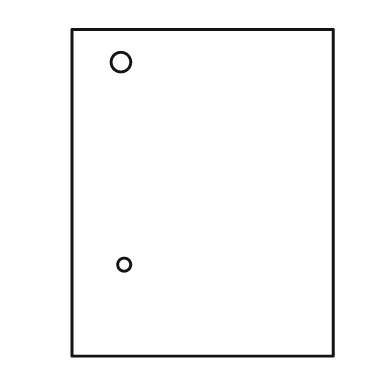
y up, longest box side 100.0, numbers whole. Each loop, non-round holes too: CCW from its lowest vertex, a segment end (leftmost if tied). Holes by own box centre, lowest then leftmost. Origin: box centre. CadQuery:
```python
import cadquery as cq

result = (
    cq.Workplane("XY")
    .moveTo(-40.0, -50.0)
    .lineTo(40.0, -50.0)
    .lineTo(40.0, 50.0)
    .lineTo(-40.0, 50.0)
    .close()
    .moveTo(-24.0, -22.0)
    .circle(2.0)
    .moveTo(-25.0, 40.0)
    .circle(3.0)
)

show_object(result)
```